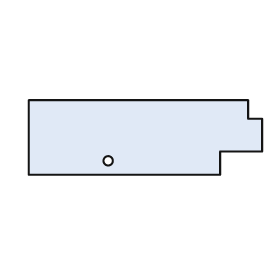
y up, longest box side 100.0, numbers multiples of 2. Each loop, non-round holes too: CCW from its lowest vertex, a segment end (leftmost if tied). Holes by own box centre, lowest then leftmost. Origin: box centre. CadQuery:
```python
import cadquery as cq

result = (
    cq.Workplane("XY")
    .moveTo(-50.0, -16.0)
    .lineTo(32.0, -16.0)
    .lineTo(32.0, -6.0)
    .lineTo(50.0, -6.0)
    .lineTo(50.0, 8.0)
    .lineTo(44.0, 8.0)
    .lineTo(44.0, 16.0)
    .lineTo(-50.0, 16.0)
    .close()
    .moveTo(-16.0, -10.0)
    .circle(2.0)
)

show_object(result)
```